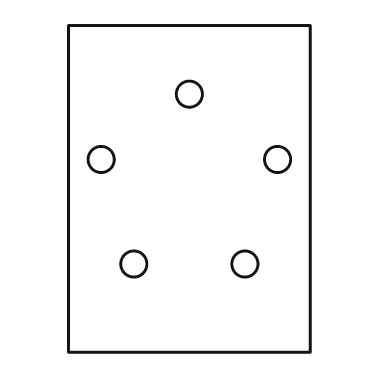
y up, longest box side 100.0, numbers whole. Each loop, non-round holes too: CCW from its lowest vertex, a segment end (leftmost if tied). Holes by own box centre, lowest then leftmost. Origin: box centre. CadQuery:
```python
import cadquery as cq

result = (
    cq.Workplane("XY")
    .moveTo(-37.0, -50.0)
    .lineTo(37.0, -50.0)
    .lineTo(37.0, 50.0)
    .lineTo(-37.0, 50.0)
    .close()
    .moveTo(-17.0, -23.0)
    .circle(4.0)
    .moveTo(17.0, -23.0)
    .circle(4.0)
    .moveTo(-27.0, 9.0)
    .circle(4.0)
    .moveTo(27.0, 9.0)
    .circle(4.0)
    .moveTo(0.0, 29.0)
    .circle(4.0)
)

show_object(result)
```